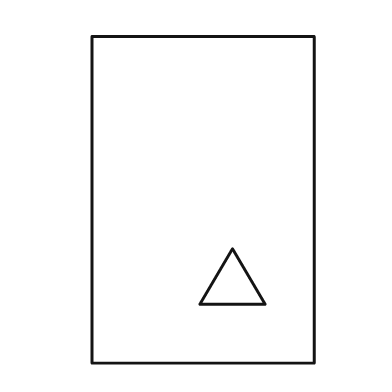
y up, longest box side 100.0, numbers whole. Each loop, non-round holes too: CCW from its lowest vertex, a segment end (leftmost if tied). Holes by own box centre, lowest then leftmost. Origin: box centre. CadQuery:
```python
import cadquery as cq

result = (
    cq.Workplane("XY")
    .moveTo(-34.0, -50.0)
    .lineTo(34.0, -50.0)
    .lineTo(34.0, 50.0)
    .lineTo(-34.0, 50.0)
    .close()
    .moveTo(-1.0, -32.0)
    .lineTo(19.0, -32.0)
    .lineTo(9.0, -15.0)
    .close()
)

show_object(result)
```